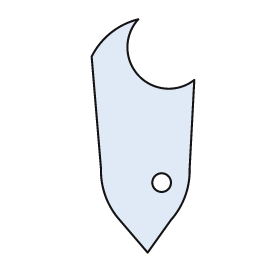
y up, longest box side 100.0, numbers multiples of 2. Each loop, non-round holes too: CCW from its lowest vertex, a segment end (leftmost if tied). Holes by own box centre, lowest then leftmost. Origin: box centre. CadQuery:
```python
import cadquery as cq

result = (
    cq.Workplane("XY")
    .moveTo(2.0, -50.0)
    .lineTo(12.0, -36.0)
    .threePointArc((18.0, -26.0), (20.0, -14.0))
    .lineTo(22.0, 24.0)
    .threePointArc((-2.0, 26.0), (-2.0, 50.0))
    .threePointArc((-14.0, 44.0), (-22.0, 34.0))
    .lineTo(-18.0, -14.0)
    .threePointArc((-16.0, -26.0), (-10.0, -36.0))
    .close()
    .moveTo(8.0, -20.0)
    .circle(4.0)
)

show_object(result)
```